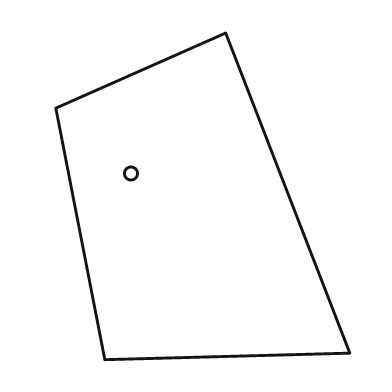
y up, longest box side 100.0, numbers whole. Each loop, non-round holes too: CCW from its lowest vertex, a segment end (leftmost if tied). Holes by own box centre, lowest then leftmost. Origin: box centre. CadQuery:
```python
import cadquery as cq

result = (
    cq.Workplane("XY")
    .moveTo(-30.0, -50.0)
    .lineTo(45.0, -48.0)
    .lineTo(7.0, 50.0)
    .lineTo(-45.0, 27.0)
    .close()
    .moveTo(-22.0, 7.0)
    .circle(2.0)
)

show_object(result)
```